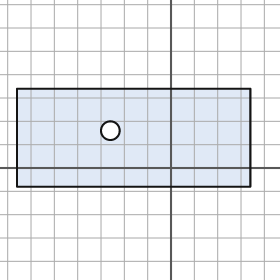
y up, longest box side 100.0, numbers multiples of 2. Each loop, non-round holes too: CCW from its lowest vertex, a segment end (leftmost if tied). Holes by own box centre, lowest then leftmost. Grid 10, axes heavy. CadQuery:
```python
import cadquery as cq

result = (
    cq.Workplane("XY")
    .moveTo(-66.0, -8.0)
    .lineTo(34.0, -8.0)
    .lineTo(34.0, 34.0)
    .lineTo(-66.0, 34.0)
    .close()
    .moveTo(-26.0, 16.0)
    .circle(4.0)
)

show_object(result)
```